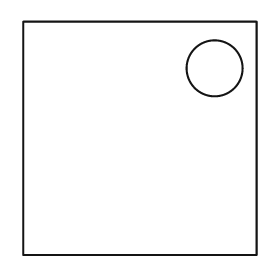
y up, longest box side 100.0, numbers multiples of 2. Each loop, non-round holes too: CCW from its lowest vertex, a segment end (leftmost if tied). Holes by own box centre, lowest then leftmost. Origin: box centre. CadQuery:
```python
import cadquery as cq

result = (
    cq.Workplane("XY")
    .moveTo(-50.0, -50.0)
    .lineTo(50.0, -50.0)
    .lineTo(50.0, 50.0)
    .lineTo(-50.0, 50.0)
    .close()
    .moveTo(32.0, 30.0)
    .circle(12.0)
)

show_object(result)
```